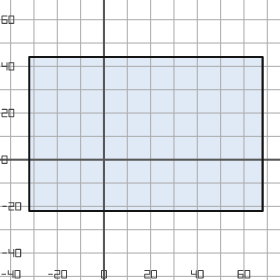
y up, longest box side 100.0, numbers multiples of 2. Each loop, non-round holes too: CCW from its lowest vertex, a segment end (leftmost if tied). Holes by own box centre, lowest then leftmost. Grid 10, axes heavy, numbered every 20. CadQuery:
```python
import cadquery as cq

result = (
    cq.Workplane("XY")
    .moveTo(-32.0, -22.0)
    .lineTo(68.0, -22.0)
    .lineTo(68.0, 44.0)
    .lineTo(-32.0, 44.0)
    .close()
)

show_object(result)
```